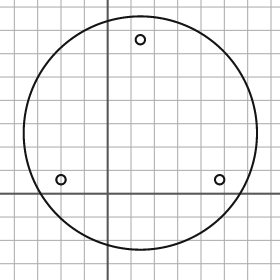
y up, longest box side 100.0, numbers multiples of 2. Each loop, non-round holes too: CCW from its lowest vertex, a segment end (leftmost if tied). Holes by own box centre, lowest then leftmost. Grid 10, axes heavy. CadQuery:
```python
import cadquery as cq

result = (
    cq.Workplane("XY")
    .moveTo(14.0, 26.0)
    .circle(50.0)
    .moveTo(-20.0, 6.0)
    .circle(2.0)
    .moveTo(48.0, 6.0)
    .circle(2.0)
    .moveTo(14.0, 66.0)
    .circle(2.0)
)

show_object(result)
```